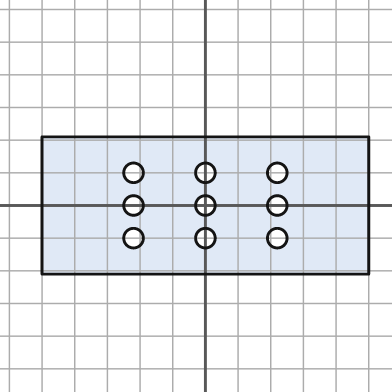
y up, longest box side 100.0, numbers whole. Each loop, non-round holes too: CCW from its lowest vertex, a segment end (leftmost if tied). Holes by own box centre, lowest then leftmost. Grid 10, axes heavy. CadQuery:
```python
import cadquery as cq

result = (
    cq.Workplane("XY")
    .moveTo(-50.0, -21.0)
    .lineTo(50.0, -21.0)
    .lineTo(50.0, 21.0)
    .lineTo(-50.0, 21.0)
    .close()
    .moveTo(-22.0, -10.0)
    .circle(3.0)
    .moveTo(0.0, -10.0)
    .circle(3.0)
    .moveTo(22.0, -10.0)
    .circle(3.0)
    .moveTo(-22.0, 0.0)
    .circle(3.0)
    .moveTo(0.0, 0.0)
    .circle(3.0)
    .moveTo(22.0, 0.0)
    .circle(3.0)
    .moveTo(-22.0, 10.0)
    .circle(3.0)
    .moveTo(0.0, 10.0)
    .circle(3.0)
    .moveTo(22.0, 10.0)
    .circle(3.0)
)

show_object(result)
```